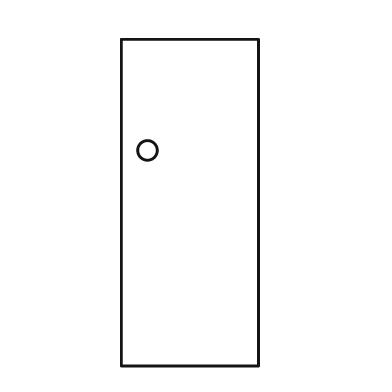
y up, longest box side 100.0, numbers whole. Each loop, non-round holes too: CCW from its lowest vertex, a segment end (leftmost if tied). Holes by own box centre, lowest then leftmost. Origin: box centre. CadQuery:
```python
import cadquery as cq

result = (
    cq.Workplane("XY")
    .moveTo(-21.0, -50.0)
    .lineTo(21.0, -50.0)
    .lineTo(21.0, 50.0)
    .lineTo(-21.0, 50.0)
    .close()
    .moveTo(-13.0, 16.0)
    .circle(3.0)
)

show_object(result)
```